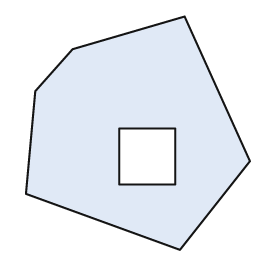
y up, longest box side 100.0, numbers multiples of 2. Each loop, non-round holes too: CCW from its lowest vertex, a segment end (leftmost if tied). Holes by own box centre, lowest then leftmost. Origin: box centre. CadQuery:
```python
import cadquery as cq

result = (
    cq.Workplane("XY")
    .moveTo(18.0, -50.0)
    .lineTo(48.0, -12.0)
    .lineTo(20.0, 50.0)
    .lineTo(-28.0, 36.0)
    .lineTo(-44.0, 18.0)
    .lineTo(-48.0, -26.0)
    .close()
    .moveTo(-8.0, -22.0)
    .lineTo(16.0, -22.0)
    .lineTo(16.0, 2.0)
    .lineTo(-8.0, 2.0)
    .close()
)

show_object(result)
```